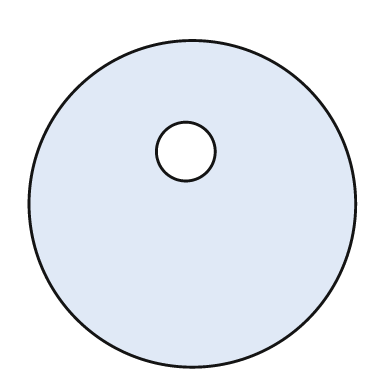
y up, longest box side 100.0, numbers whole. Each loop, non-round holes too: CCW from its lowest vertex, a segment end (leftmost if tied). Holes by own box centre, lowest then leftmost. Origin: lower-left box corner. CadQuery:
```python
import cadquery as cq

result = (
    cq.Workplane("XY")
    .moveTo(50.0, 50.0)
    .circle(50.0)
    .moveTo(48.0, 66.0)
    .circle(9.0)
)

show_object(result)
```